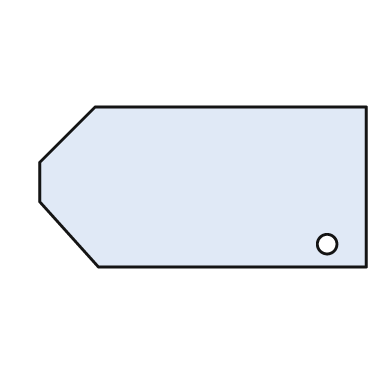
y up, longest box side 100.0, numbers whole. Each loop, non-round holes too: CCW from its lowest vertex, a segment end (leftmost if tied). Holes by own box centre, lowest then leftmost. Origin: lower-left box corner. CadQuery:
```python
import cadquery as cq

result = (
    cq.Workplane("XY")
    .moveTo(18.0, 0.0)
    .lineTo(100.0, 0.0)
    .lineTo(100.0, 49.0)
    .lineTo(17.0, 49.0)
    .lineTo(0.0, 32.0)
    .lineTo(0.0, 20.0)
    .close()
    .moveTo(88.0, 7.0)
    .circle(3.0)
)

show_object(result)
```